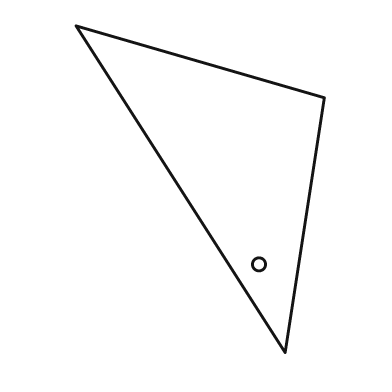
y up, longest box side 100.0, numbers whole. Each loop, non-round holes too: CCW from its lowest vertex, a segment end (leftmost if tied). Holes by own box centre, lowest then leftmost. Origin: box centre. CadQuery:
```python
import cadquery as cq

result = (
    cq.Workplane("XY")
    .moveTo(26.0, -50.0)
    .lineTo(38.0, 28.0)
    .lineTo(-38.0, 50.0)
    .close()
    .moveTo(18.0, -23.0)
    .circle(2.0)
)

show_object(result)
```